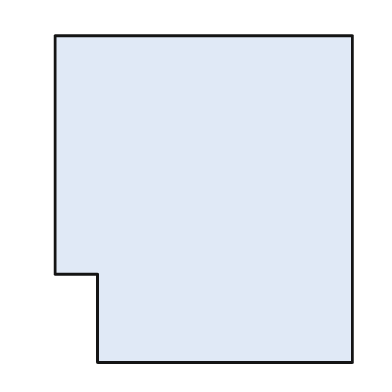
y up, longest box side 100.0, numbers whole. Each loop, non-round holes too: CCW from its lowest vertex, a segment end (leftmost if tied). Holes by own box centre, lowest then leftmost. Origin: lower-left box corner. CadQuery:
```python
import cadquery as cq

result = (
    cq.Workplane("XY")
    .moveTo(13.0, 0.0)
    .lineTo(91.0, 0.0)
    .lineTo(91.0, 100.0)
    .lineTo(0.0, 100.0)
    .lineTo(0.0, 27.0)
    .lineTo(13.0, 27.0)
    .close()
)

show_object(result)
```